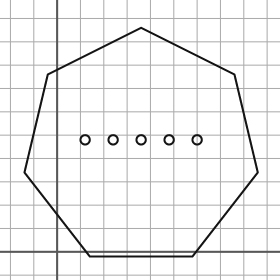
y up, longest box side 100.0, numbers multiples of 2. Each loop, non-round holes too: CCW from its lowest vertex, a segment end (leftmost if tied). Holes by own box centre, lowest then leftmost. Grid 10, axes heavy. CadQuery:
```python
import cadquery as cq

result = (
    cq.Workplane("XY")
    .moveTo(14.0, -2.0)
    .lineTo(58.0, -2.0)
    .lineTo(86.0, 34.0)
    .lineTo(76.0, 76.0)
    .lineTo(36.0, 96.0)
    .lineTo(-4.0, 76.0)
    .lineTo(-14.0, 34.0)
    .close()
    .moveTo(12.0, 48.0)
    .circle(2.0)
    .moveTo(24.0, 48.0)
    .circle(2.0)
    .moveTo(36.0, 48.0)
    .circle(2.0)
    .moveTo(48.0, 48.0)
    .circle(2.0)
    .moveTo(60.0, 48.0)
    .circle(2.0)
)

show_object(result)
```